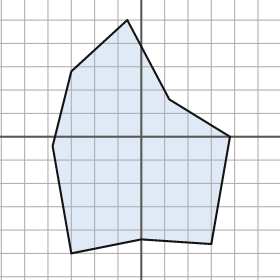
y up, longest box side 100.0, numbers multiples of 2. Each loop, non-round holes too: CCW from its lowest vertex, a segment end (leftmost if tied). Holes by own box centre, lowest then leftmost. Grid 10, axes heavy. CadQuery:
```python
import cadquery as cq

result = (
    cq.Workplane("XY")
    .moveTo(-30.0, -50.0)
    .lineTo(0.0, -44.0)
    .lineTo(30.0, -46.0)
    .lineTo(38.0, 0.0)
    .lineTo(12.0, 16.0)
    .lineTo(-6.0, 50.0)
    .lineTo(-30.0, 28.0)
    .lineTo(-38.0, -4.0)
    .close()
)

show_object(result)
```